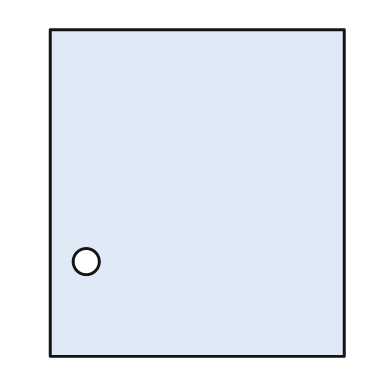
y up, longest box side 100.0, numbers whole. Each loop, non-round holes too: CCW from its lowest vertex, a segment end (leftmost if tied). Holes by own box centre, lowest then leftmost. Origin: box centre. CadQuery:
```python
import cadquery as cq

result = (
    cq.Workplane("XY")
    .moveTo(-45.0, -50.0)
    .lineTo(45.0, -50.0)
    .lineTo(45.0, 50.0)
    .lineTo(-45.0, 50.0)
    .close()
    .moveTo(-34.0, -21.0)
    .circle(4.0)
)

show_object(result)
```